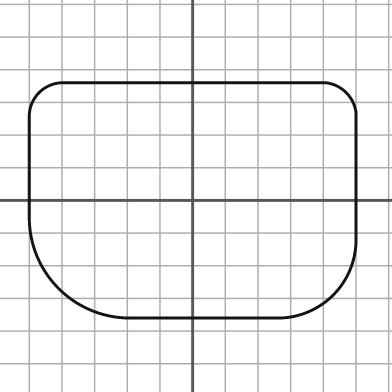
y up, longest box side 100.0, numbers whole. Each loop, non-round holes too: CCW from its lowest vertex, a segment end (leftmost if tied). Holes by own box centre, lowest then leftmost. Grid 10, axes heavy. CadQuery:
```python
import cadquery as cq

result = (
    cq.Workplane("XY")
    .moveTo(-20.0, -36.0)
    .lineTo(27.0, -36.0)
    .threePointArc((43.0, -29.0), (50.0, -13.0))
    .lineTo(50.0, 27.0)
    .threePointArc((47.0, 33.0), (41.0, 36.0))
    .lineTo(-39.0, 36.0)
    .threePointArc((-47.0, 33.0), (-50.0, 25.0))
    .lineTo(-50.0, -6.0)
    .threePointArc((-41.0, -27.0), (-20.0, -36.0))
    .close()
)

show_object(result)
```